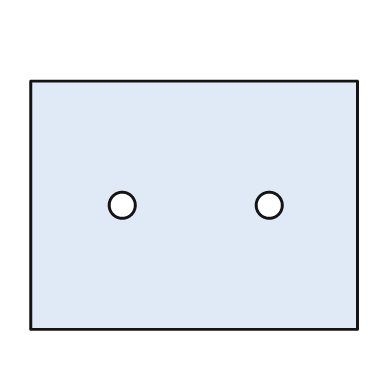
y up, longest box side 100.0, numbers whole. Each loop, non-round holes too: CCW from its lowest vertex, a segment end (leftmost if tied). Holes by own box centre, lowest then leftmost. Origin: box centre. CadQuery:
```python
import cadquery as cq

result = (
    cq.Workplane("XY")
    .moveTo(-50.0, -38.0)
    .lineTo(50.0, -38.0)
    .lineTo(50.0, 38.0)
    .lineTo(-50.0, 38.0)
    .close()
    .moveTo(-22.0, 0.0)
    .circle(4.0)
    .moveTo(23.0, 0.0)
    .circle(4.0)
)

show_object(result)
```